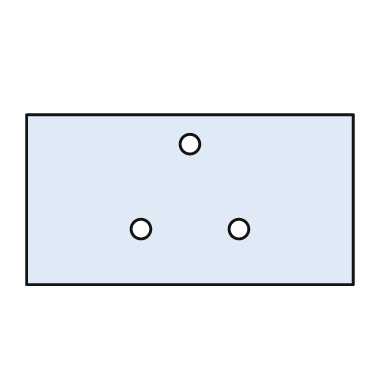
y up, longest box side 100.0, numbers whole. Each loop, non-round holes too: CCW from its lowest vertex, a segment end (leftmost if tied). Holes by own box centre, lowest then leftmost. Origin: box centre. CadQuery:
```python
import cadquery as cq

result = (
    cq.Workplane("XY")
    .moveTo(-50.0, -26.0)
    .lineTo(50.0, -26.0)
    .lineTo(50.0, 26.0)
    .lineTo(-50.0, 26.0)
    .close()
    .moveTo(-15.0, -9.0)
    .circle(3.0)
    .moveTo(15.0, -9.0)
    .circle(3.0)
    .moveTo(0.0, 17.0)
    .circle(3.0)
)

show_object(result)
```